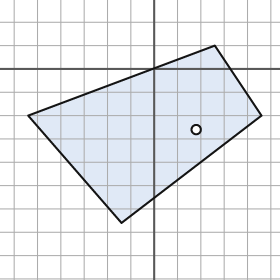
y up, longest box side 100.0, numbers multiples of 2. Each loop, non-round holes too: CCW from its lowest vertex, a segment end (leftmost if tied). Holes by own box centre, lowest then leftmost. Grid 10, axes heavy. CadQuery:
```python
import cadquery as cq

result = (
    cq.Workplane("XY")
    .moveTo(-14.0, -66.0)
    .lineTo(46.0, -20.0)
    .lineTo(26.0, 10.0)
    .lineTo(-54.0, -20.0)
    .close()
    .moveTo(18.0, -26.0)
    .circle(2.0)
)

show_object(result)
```